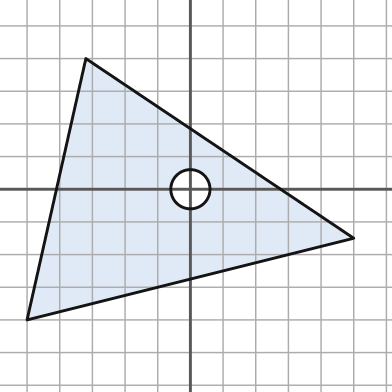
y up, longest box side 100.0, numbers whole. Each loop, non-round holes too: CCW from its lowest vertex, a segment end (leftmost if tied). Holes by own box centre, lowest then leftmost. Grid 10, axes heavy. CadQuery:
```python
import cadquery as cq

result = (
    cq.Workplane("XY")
    .moveTo(-50.0, -40.0)
    .lineTo(50.0, -15.0)
    .lineTo(-32.0, 40.0)
    .close()
    .moveTo(0.0, 0.0)
    .circle(6.0)
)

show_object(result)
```